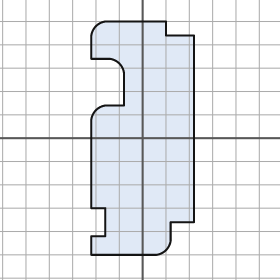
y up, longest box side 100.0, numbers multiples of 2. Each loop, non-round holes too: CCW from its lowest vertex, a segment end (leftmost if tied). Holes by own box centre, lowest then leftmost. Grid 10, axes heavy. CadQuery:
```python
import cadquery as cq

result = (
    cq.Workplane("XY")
    .moveTo(-22.0, -50.0)
    .lineTo(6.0, -50.0)
    .threePointArc((10.0, -48.0), (12.0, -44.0))
    .lineTo(12.0, -36.0)
    .lineTo(22.0, -36.0)
    .lineTo(22.0, 44.0)
    .lineTo(10.0, 44.0)
    .lineTo(10.0, 50.0)
    .lineTo(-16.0, 50.0)
    .threePointArc((-20.0, 48.0), (-22.0, 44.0))
    .lineTo(-22.0, 34.0)
    .lineTo(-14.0, 34.0)
    .threePointArc((-10.0, 32.0), (-8.0, 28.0))
    .lineTo(-8.0, 14.0)
    .lineTo(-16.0, 14.0)
    .threePointArc((-20.0, 12.0), (-22.0, 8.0))
    .lineTo(-22.0, -30.0)
    .lineTo(-16.0, -30.0)
    .lineTo(-16.0, -42.0)
    .lineTo(-22.0, -42.0)
    .close()
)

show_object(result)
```